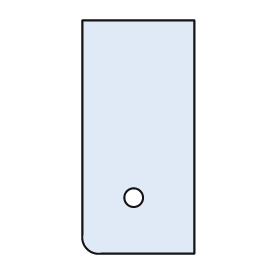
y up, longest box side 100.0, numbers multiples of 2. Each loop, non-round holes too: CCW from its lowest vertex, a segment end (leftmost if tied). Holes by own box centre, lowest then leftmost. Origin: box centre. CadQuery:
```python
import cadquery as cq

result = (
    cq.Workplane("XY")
    .moveTo(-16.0, -50.0)
    .lineTo(24.0, -50.0)
    .lineTo(24.0, 50.0)
    .lineTo(-24.0, 50.0)
    .lineTo(-24.0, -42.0)
    .threePointArc((-22.0, -48.0), (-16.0, -50.0))
    .close()
    .moveTo(-2.0, -26.0)
    .circle(4.0)
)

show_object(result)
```